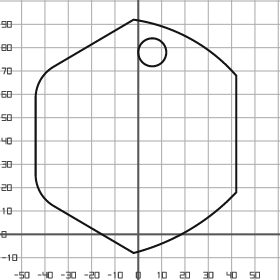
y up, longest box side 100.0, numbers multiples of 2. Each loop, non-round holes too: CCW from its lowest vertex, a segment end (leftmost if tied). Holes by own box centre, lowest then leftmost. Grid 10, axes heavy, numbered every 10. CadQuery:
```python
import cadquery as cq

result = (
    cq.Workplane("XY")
    .moveTo(-2.0, -8.0)
    .threePointArc((22.0, 2.0), (42.0, 18.0))
    .lineTo(42.0, 68.0)
    .threePointArc((22.0, 84.0), (-2.0, 92.0))
    .lineTo(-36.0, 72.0)
    .threePointArc((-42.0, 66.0), (-44.0, 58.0))
    .lineTo(-44.0, 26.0)
    .threePointArc((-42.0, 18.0), (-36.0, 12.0))
    .close()
    .moveTo(6.0, 78.0)
    .circle(6.0)
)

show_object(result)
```